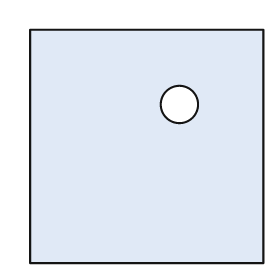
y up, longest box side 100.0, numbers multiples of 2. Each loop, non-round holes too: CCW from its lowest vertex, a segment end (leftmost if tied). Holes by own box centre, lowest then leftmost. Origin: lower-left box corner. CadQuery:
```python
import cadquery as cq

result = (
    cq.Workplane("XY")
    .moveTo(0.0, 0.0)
    .lineTo(100.0, 0.0)
    .lineTo(100.0, 100.0)
    .lineTo(0.0, 100.0)
    .close()
    .moveTo(64.0, 68.0)
    .circle(8.0)
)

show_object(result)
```